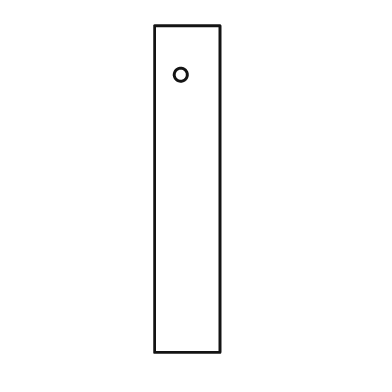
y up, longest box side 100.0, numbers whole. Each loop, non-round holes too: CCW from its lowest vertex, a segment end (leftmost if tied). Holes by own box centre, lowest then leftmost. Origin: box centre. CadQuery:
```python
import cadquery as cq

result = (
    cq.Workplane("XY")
    .moveTo(-10.0, -50.0)
    .lineTo(10.0, -50.0)
    .lineTo(10.0, 50.0)
    .lineTo(-10.0, 50.0)
    .close()
    .moveTo(-2.0, 35.0)
    .circle(2.0)
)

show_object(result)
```